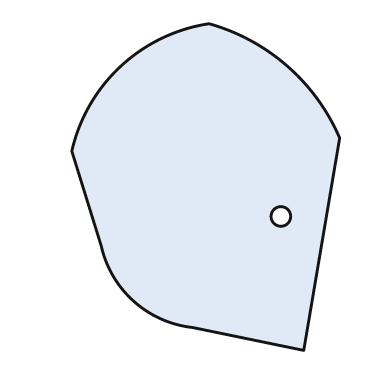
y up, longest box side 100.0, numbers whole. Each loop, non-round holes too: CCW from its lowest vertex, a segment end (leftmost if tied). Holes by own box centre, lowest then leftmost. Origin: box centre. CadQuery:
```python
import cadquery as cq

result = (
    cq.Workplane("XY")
    .moveTo(30.0, -50.0)
    .lineTo(41.0, 15.0)
    .threePointArc((25.0, 37.0), (1.0, 50.0))
    .threePointArc((-26.0, 37.0), (-41.0, 11.0))
    .lineTo(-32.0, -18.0)
    .threePointArc((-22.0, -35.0), (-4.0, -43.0))
    .close()
    .moveTo(23.0, -9.0)
    .circle(3.0)
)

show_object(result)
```